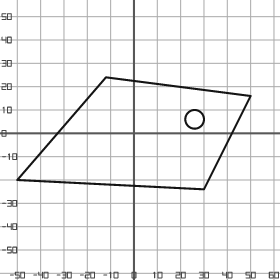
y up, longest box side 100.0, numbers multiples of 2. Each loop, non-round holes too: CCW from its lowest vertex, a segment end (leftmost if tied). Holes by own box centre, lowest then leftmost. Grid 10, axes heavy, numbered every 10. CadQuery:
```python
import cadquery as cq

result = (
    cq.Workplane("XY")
    .moveTo(30.0, -24.0)
    .lineTo(50.0, 16.0)
    .lineTo(-12.0, 24.0)
    .lineTo(-50.0, -20.0)
    .close()
    .moveTo(26.0, 6.0)
    .circle(4.0)
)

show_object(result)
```